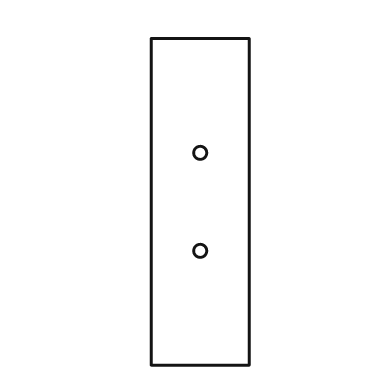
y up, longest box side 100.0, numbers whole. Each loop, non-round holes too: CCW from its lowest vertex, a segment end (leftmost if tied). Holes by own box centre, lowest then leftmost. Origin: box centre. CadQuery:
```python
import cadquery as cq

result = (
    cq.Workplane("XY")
    .moveTo(-15.0, -50.0)
    .lineTo(15.0, -50.0)
    .lineTo(15.0, 50.0)
    .lineTo(-15.0, 50.0)
    .close()
    .moveTo(0.0, -15.0)
    .circle(2.0)
    .moveTo(0.0, 15.0)
    .circle(2.0)
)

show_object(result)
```